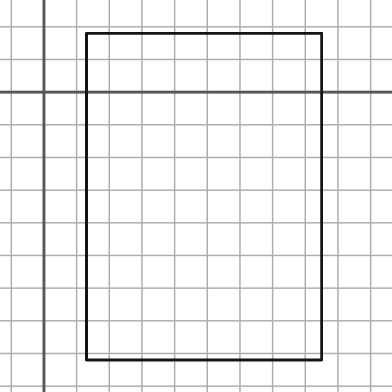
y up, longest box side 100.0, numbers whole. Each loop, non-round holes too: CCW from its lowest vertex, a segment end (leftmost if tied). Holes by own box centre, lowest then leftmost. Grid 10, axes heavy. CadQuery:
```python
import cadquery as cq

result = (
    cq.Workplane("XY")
    .moveTo(13.0, -82.0)
    .lineTo(85.0, -82.0)
    .lineTo(85.0, 18.0)
    .lineTo(13.0, 18.0)
    .close()
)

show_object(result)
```